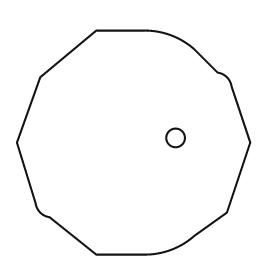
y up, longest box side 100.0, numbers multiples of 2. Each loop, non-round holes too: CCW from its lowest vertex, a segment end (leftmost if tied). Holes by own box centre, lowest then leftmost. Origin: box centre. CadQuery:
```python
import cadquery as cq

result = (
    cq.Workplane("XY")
    .moveTo(-16.0, -48.0)
    .lineTo(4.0, -48.0)
    .threePointArc((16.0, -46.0), (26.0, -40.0))
    .lineTo(40.0, -30.0)
    .lineTo(50.0, 0.0)
    .lineTo(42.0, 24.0)
    .threePointArc((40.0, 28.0), (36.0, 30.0))
    .lineTo(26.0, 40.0)
    .threePointArc((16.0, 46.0), (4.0, 48.0))
    .lineTo(-16.0, 48.0)
    .lineTo(-40.0, 28.0)
    .lineTo(-50.0, 0.0)
    .lineTo(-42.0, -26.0)
    .threePointArc((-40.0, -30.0), (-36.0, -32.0))
    .close()
    .moveTo(18.0, 2.0)
    .circle(4.0)
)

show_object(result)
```